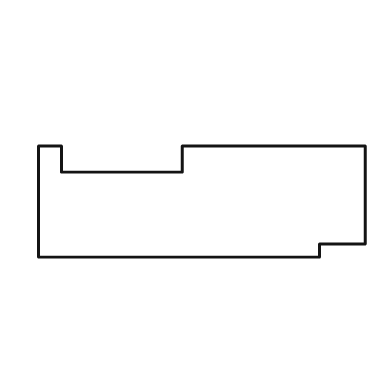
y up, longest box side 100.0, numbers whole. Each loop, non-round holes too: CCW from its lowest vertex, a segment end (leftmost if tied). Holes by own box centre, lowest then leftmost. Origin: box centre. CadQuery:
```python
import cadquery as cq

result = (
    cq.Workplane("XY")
    .moveTo(-50.0, -17.0)
    .lineTo(36.0, -17.0)
    .lineTo(36.0, -13.0)
    .lineTo(50.0, -13.0)
    .lineTo(50.0, 17.0)
    .lineTo(-6.0, 17.0)
    .lineTo(-6.0, 9.0)
    .lineTo(-43.0, 9.0)
    .lineTo(-43.0, 17.0)
    .lineTo(-50.0, 17.0)
    .close()
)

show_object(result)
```